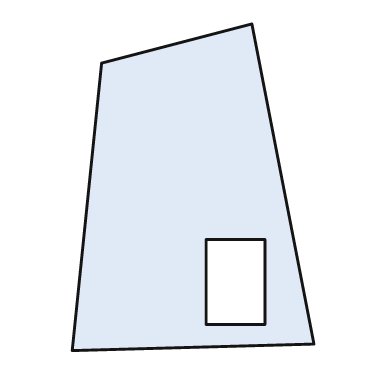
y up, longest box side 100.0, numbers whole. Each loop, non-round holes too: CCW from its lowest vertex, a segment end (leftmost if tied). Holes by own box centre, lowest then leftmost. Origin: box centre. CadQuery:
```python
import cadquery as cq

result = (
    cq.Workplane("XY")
    .moveTo(-37.0, -50.0)
    .lineTo(37.0, -48.0)
    .lineTo(18.0, 50.0)
    .lineTo(-28.0, 38.0)
    .close()
    .moveTo(4.0, -42.0)
    .lineTo(22.0, -42.0)
    .lineTo(22.0, -16.0)
    .lineTo(4.0, -16.0)
    .close()
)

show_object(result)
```